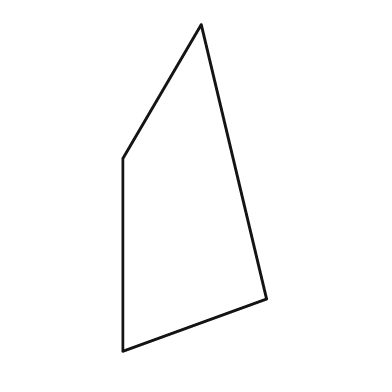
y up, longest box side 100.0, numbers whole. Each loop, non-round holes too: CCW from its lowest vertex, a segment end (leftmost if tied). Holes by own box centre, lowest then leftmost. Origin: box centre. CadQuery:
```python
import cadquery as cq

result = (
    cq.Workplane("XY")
    .moveTo(-22.0, -50.0)
    .lineTo(22.0, -34.0)
    .lineTo(2.0, 50.0)
    .lineTo(-22.0, 9.0)
    .close()
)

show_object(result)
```